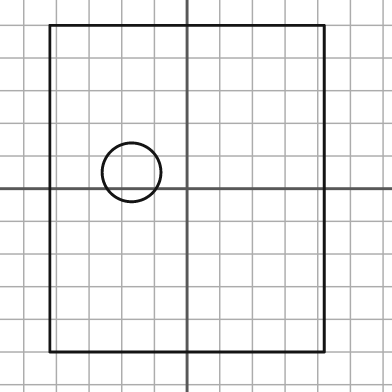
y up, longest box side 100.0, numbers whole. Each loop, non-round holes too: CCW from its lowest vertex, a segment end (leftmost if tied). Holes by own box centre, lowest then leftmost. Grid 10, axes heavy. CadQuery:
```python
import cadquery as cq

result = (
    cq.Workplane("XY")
    .moveTo(-42.0, -50.0)
    .lineTo(42.0, -50.0)
    .lineTo(42.0, 50.0)
    .lineTo(-42.0, 50.0)
    .close()
    .moveTo(-17.0, 5.0)
    .circle(9.0)
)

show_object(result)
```